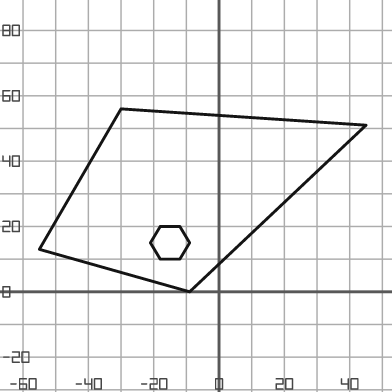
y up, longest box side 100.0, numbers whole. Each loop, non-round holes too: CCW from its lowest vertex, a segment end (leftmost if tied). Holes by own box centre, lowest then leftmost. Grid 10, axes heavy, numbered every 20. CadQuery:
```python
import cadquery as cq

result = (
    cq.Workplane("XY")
    .moveTo(-9.0, 0.0)
    .lineTo(45.0, 51.0)
    .lineTo(-30.0, 56.0)
    .lineTo(-55.0, 13.0)
    .close()
    .moveTo(-18.0, 10.0)
    .lineTo(-12.0, 10.0)
    .lineTo(-9.0, 15.0)
    .lineTo(-12.0, 20.0)
    .lineTo(-18.0, 20.0)
    .lineTo(-21.0, 15.0)
    .close()
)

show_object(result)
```